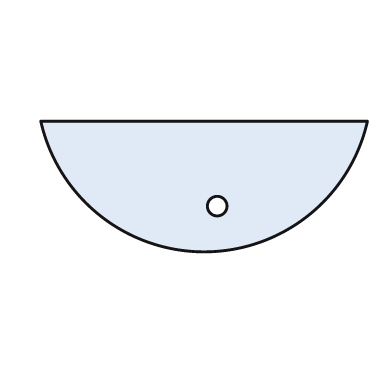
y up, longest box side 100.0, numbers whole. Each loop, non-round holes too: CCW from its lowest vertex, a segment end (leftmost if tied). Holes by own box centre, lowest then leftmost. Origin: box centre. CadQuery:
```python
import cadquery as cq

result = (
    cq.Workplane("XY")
    .moveTo(-50.0, 20.0)
    .threePointArc((0.0, -20.0), (50.0, 20.0))
    .close()
    .moveTo(4.0, -6.0)
    .circle(3.0)
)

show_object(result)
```